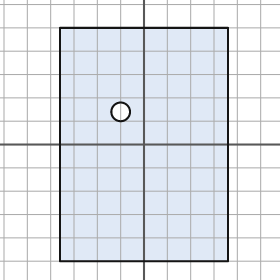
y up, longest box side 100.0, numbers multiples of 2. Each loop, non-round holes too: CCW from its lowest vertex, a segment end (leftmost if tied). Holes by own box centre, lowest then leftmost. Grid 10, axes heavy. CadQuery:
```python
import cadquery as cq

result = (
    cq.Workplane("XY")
    .moveTo(-36.0, -50.0)
    .lineTo(36.0, -50.0)
    .lineTo(36.0, 50.0)
    .lineTo(-36.0, 50.0)
    .close()
    .moveTo(-10.0, 14.0)
    .circle(4.0)
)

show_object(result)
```